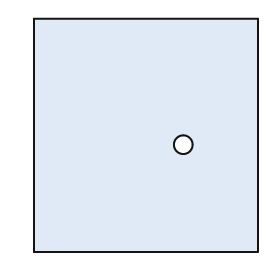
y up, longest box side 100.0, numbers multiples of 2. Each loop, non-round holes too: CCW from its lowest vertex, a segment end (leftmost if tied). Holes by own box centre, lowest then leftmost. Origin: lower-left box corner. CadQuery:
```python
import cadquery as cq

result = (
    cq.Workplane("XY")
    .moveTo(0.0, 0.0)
    .lineTo(96.0, 0.0)
    .lineTo(96.0, 100.0)
    .lineTo(0.0, 100.0)
    .close()
    .moveTo(64.0, 46.0)
    .circle(4.0)
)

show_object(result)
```